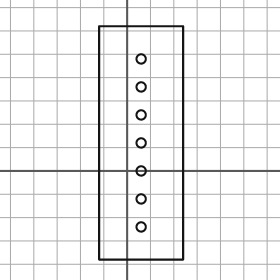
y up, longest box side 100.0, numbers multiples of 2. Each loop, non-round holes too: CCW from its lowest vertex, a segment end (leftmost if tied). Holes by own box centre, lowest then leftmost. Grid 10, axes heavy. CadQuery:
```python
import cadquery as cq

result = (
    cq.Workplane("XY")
    .moveTo(-12.0, -38.0)
    .lineTo(24.0, -38.0)
    .lineTo(24.0, 62.0)
    .lineTo(-12.0, 62.0)
    .close()
    .moveTo(6.0, -24.0)
    .circle(2.0)
    .moveTo(6.0, -12.0)
    .circle(2.0)
    .moveTo(6.0, 0.0)
    .circle(2.0)
    .moveTo(6.0, 12.0)
    .circle(2.0)
    .moveTo(6.0, 24.0)
    .circle(2.0)
    .moveTo(6.0, 36.0)
    .circle(2.0)
    .moveTo(6.0, 48.0)
    .circle(2.0)
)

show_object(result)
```